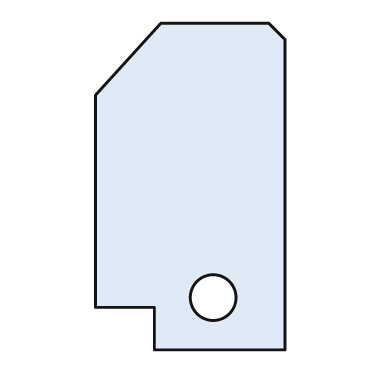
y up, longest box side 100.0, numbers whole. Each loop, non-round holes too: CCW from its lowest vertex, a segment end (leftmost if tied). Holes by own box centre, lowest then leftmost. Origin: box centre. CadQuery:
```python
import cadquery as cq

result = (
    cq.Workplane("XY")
    .moveTo(-11.0, -50.0)
    .lineTo(29.0, -50.0)
    .lineTo(29.0, 45.0)
    .lineTo(24.0, 50.0)
    .lineTo(-9.0, 50.0)
    .lineTo(-29.0, 28.0)
    .lineTo(-29.0, -37.0)
    .lineTo(-11.0, -37.0)
    .close()
    .moveTo(7.0, -34.0)
    .circle(7.0)
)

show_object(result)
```